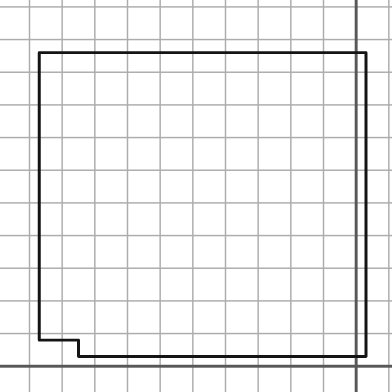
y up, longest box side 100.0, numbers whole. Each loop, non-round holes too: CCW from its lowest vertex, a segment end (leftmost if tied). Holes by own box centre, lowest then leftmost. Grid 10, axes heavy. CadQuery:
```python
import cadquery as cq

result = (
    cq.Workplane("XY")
    .moveTo(-85.0, 3.0)
    .lineTo(3.0, 3.0)
    .lineTo(3.0, 96.0)
    .lineTo(-97.0, 96.0)
    .lineTo(-97.0, 8.0)
    .lineTo(-85.0, 8.0)
    .close()
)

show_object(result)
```